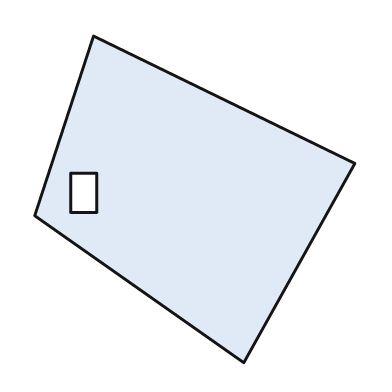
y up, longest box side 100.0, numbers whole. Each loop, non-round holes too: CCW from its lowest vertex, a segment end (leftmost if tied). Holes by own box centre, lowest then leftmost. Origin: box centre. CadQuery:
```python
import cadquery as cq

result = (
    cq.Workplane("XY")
    .moveTo(15.0, -50.0)
    .lineTo(49.0, 11.0)
    .lineTo(-31.0, 50.0)
    .lineTo(-49.0, -5.0)
    .close()
    .moveTo(-38.0, -4.0)
    .lineTo(-30.0, -4.0)
    .lineTo(-30.0, 8.0)
    .lineTo(-38.0, 8.0)
    .close()
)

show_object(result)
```